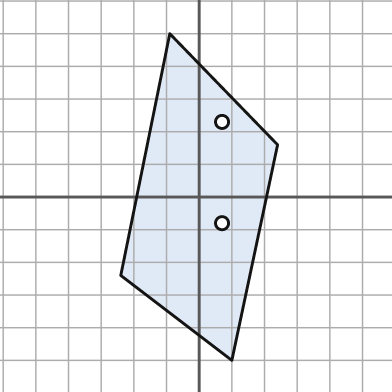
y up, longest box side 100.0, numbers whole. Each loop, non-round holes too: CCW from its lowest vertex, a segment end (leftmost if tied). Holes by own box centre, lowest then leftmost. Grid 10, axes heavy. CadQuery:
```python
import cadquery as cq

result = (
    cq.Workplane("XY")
    .moveTo(10.0, -50.0)
    .lineTo(24.0, 16.0)
    .lineTo(-9.0, 50.0)
    .lineTo(-24.0, -24.0)
    .close()
    .moveTo(7.0, -8.0)
    .circle(2.0)
    .moveTo(7.0, 23.0)
    .circle(2.0)
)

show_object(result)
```